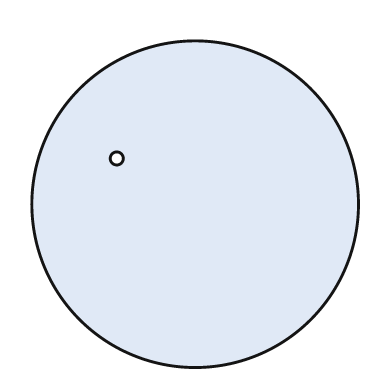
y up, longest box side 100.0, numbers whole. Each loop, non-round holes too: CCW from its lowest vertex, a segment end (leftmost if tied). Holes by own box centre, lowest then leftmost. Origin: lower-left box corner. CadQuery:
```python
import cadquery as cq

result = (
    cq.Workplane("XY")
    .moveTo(50.0, 50.0)
    .circle(50.0)
    .moveTo(26.0, 64.0)
    .circle(2.0)
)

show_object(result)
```